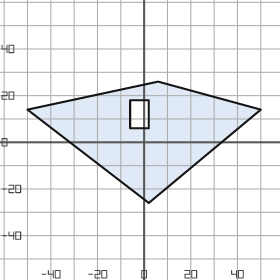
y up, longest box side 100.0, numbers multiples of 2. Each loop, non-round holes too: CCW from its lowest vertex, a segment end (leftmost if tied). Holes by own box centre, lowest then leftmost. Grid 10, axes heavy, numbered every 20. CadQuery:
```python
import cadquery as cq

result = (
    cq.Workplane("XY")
    .moveTo(2.0, -26.0)
    .lineTo(50.0, 14.0)
    .lineTo(6.0, 26.0)
    .lineTo(-50.0, 14.0)
    .close()
    .moveTo(-6.0, 6.0)
    .lineTo(2.0, 6.0)
    .lineTo(2.0, 18.0)
    .lineTo(-6.0, 18.0)
    .close()
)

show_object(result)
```